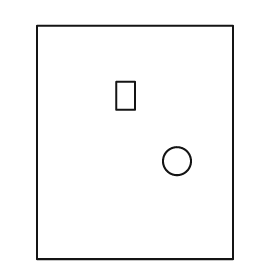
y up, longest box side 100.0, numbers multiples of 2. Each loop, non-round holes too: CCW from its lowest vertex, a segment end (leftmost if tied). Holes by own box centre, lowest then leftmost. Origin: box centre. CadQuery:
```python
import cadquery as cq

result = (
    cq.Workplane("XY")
    .moveTo(-42.0, -50.0)
    .lineTo(42.0, -50.0)
    .lineTo(42.0, 50.0)
    .lineTo(-42.0, 50.0)
    .close()
    .moveTo(18.0, -8.0)
    .circle(6.0)
    .moveTo(-8.0, 14.0)
    .lineTo(0.0, 14.0)
    .lineTo(0.0, 26.0)
    .lineTo(-8.0, 26.0)
    .close()
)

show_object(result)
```